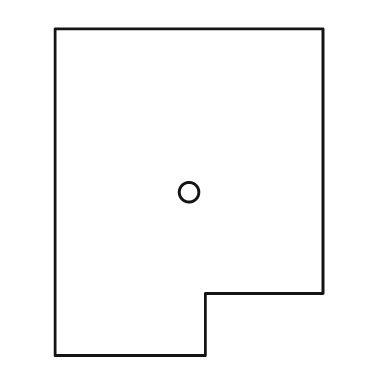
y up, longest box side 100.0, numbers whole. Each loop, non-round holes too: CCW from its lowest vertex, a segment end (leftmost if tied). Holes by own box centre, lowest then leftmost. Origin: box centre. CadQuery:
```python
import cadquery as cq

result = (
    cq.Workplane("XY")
    .moveTo(-41.0, -50.0)
    .lineTo(5.0, -50.0)
    .lineTo(5.0, -31.0)
    .lineTo(41.0, -31.0)
    .lineTo(41.0, 50.0)
    .lineTo(-41.0, 50.0)
    .close()
    .moveTo(0.0, 0.0)
    .circle(3.0)
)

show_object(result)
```